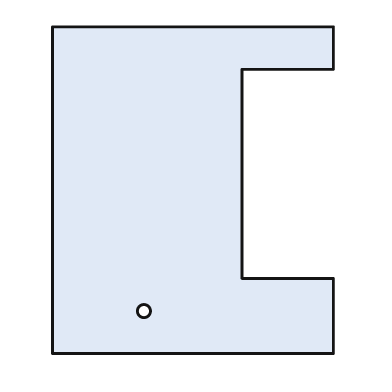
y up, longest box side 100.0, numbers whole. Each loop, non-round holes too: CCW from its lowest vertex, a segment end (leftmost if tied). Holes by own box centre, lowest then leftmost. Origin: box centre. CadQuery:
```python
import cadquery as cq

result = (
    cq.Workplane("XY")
    .moveTo(-43.0, -50.0)
    .lineTo(43.0, -50.0)
    .lineTo(43.0, -27.0)
    .lineTo(15.0, -27.0)
    .lineTo(15.0, 37.0)
    .lineTo(43.0, 37.0)
    .lineTo(43.0, 50.0)
    .lineTo(-43.0, 50.0)
    .close()
    .moveTo(-15.0, -37.0)
    .circle(2.0)
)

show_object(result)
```